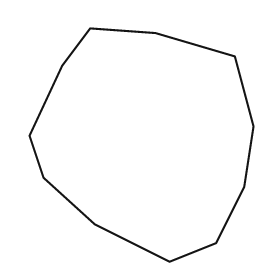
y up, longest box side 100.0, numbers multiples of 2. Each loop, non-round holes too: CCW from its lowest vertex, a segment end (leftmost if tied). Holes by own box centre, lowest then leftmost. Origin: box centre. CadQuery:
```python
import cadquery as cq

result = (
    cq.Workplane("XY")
    .moveTo(12.0, -50.0)
    .lineTo(32.0, -42.0)
    .lineTo(44.0, -18.0)
    .lineTo(48.0, 8.0)
    .lineTo(40.0, 38.0)
    .lineTo(6.0, 48.0)
    .lineTo(-22.0, 50.0)
    .lineTo(-34.0, 34.0)
    .lineTo(-48.0, 4.0)
    .lineTo(-42.0, -14.0)
    .lineTo(-20.0, -34.0)
    .close()
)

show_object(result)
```